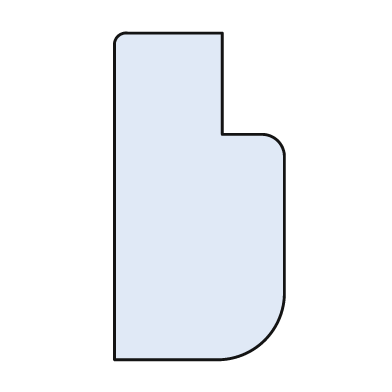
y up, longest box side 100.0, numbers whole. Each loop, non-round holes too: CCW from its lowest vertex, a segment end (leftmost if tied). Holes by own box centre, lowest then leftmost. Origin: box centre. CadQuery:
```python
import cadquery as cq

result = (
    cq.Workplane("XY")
    .moveTo(-26.0, -50.0)
    .lineTo(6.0, -50.0)
    .threePointArc((20.0, -44.0), (26.0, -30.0))
    .lineTo(26.0, 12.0)
    .threePointArc((24.0, 17.0), (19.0, 19.0))
    .lineTo(7.0, 19.0)
    .lineTo(7.0, 50.0)
    .lineTo(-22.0, 50.0)
    .threePointArc((-25.0, 49.0), (-26.0, 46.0))
    .close()
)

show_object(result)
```